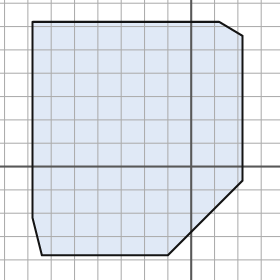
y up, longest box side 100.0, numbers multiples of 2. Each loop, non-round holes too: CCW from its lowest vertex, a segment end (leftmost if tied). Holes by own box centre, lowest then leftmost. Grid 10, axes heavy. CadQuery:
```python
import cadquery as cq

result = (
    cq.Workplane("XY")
    .moveTo(-64.0, -38.0)
    .lineTo(-10.0, -38.0)
    .lineTo(22.0, -6.0)
    .lineTo(22.0, 56.0)
    .lineTo(12.0, 62.0)
    .lineTo(-68.0, 62.0)
    .lineTo(-68.0, -22.0)
    .close()
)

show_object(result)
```